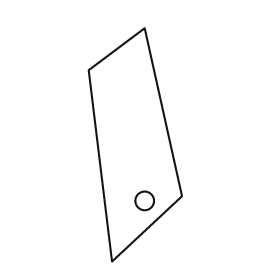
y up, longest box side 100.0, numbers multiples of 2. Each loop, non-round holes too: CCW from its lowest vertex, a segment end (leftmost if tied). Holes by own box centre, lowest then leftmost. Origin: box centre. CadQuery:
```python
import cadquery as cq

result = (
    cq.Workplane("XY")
    .moveTo(-10.0, -50.0)
    .lineTo(20.0, -22.0)
    .lineTo(4.0, 50.0)
    .lineTo(-20.0, 32.0)
    .close()
    .moveTo(4.0, -24.0)
    .circle(4.0)
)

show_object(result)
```